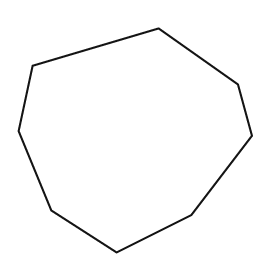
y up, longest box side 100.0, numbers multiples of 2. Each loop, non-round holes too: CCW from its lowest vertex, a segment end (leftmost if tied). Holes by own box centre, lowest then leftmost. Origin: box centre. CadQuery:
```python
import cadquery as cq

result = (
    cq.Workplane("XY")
    .moveTo(-8.0, -48.0)
    .lineTo(24.0, -32.0)
    .lineTo(50.0, 2.0)
    .lineTo(44.0, 24.0)
    .lineTo(10.0, 48.0)
    .lineTo(-44.0, 32.0)
    .lineTo(-50.0, 4.0)
    .lineTo(-36.0, -30.0)
    .close()
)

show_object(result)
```